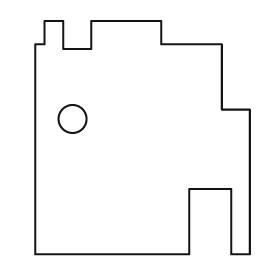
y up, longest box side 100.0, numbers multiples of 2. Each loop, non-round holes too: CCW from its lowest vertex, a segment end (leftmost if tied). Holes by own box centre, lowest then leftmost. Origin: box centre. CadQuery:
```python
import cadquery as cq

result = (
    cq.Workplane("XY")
    .moveTo(-46.0, -50.0)
    .lineTo(20.0, -50.0)
    .lineTo(20.0, -22.0)
    .lineTo(38.0, -22.0)
    .lineTo(38.0, -50.0)
    .lineTo(46.0, -50.0)
    .lineTo(46.0, 12.0)
    .lineTo(34.0, 12.0)
    .lineTo(34.0, 40.0)
    .lineTo(8.0, 40.0)
    .lineTo(8.0, 50.0)
    .lineTo(-22.0, 50.0)
    .lineTo(-22.0, 38.0)
    .lineTo(-34.0, 38.0)
    .lineTo(-34.0, 50.0)
    .lineTo(-42.0, 50.0)
    .lineTo(-42.0, 40.0)
    .lineTo(-46.0, 40.0)
    .close()
    .moveTo(-30.0, 8.0)
    .circle(6.0)
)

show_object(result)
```